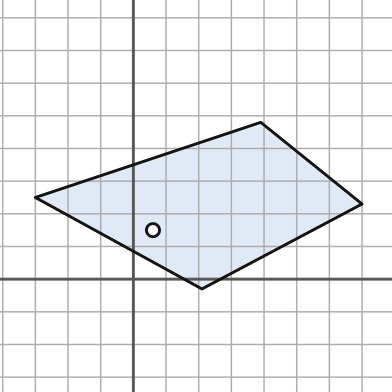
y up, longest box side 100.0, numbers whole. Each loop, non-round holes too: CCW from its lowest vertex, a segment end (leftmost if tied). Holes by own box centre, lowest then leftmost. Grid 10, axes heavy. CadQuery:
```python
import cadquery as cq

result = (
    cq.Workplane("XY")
    .moveTo(21.0, -3.0)
    .lineTo(70.0, 23.0)
    .lineTo(39.0, 48.0)
    .lineTo(-30.0, 25.0)
    .close()
    .moveTo(6.0, 15.0)
    .circle(2.0)
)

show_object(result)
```